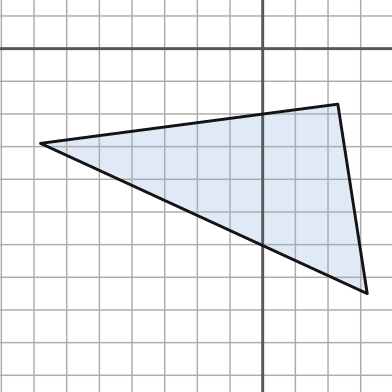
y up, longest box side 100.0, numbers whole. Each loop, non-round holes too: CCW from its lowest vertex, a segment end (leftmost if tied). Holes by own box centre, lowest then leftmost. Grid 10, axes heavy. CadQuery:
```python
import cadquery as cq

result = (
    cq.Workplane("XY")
    .moveTo(32.0, -75.0)
    .lineTo(23.0, -17.0)
    .lineTo(-68.0, -29.0)
    .close()
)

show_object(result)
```